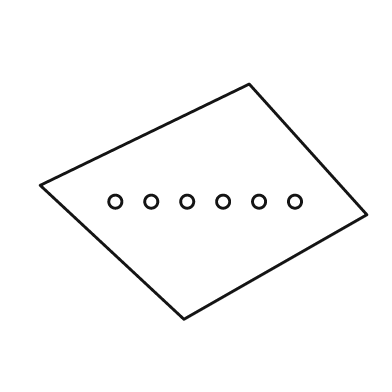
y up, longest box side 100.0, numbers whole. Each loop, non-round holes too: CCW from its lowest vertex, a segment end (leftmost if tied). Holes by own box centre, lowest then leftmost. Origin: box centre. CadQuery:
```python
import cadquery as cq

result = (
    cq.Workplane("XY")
    .moveTo(-6.0, -36.0)
    .lineTo(50.0, -4.0)
    .lineTo(14.0, 36.0)
    .lineTo(-50.0, 5.0)
    .close()
    .moveTo(-27.0, 0.0)
    .circle(2.0)
    .moveTo(-16.0, 0.0)
    .circle(2.0)
    .moveTo(-5.0, 0.0)
    .circle(2.0)
    .moveTo(6.0, 0.0)
    .circle(2.0)
    .moveTo(17.0, 0.0)
    .circle(2.0)
    .moveTo(28.0, 0.0)
    .circle(2.0)
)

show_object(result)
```